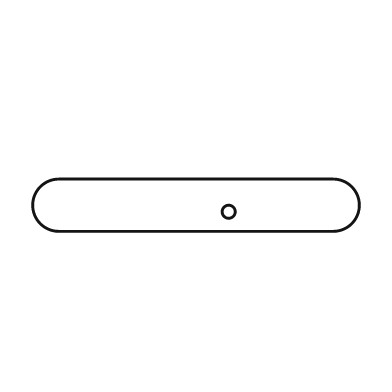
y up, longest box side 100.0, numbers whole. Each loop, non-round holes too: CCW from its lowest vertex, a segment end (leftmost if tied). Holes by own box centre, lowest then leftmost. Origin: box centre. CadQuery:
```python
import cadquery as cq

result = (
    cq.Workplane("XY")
    .moveTo(-42.0, -8.0)
    .lineTo(42.0, -8.0)
    .threePointArc((50.0, 0.0), (42.0, 8.0))
    .lineTo(-42.0, 8.0)
    .threePointArc((-50.0, 0.0), (-42.0, -8.0))
    .close()
    .moveTo(10.0, -2.0)
    .circle(2.0)
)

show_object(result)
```